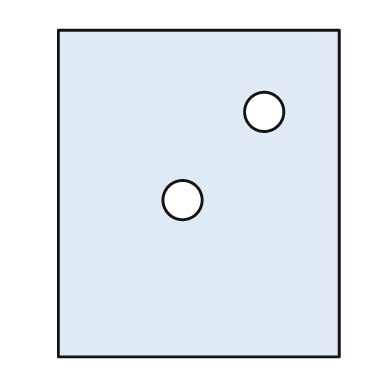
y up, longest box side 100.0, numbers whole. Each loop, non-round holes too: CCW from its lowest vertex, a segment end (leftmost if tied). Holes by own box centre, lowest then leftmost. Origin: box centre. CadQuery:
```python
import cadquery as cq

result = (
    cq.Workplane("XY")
    .moveTo(-43.0, -50.0)
    .lineTo(43.0, -50.0)
    .lineTo(43.0, 50.0)
    .lineTo(-43.0, 50.0)
    .close()
    .moveTo(-5.0, -2.0)
    .circle(6.0)
    .moveTo(20.0, 25.0)
    .circle(6.0)
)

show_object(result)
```